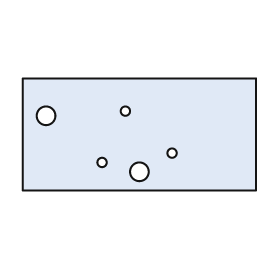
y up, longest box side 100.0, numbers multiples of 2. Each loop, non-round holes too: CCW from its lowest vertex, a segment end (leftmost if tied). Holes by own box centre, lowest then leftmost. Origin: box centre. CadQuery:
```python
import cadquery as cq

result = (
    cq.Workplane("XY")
    .moveTo(-50.0, -24.0)
    .lineTo(50.0, -24.0)
    .lineTo(50.0, 24.0)
    .lineTo(-50.0, 24.0)
    .close()
    .moveTo(0.0, -16.0)
    .circle(4.0)
    .moveTo(-16.0, -12.0)
    .circle(2.0)
    .moveTo(14.0, -8.0)
    .circle(2.0)
    .moveTo(-40.0, 8.0)
    .circle(4.0)
    .moveTo(-6.0, 10.0)
    .circle(2.0)
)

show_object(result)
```